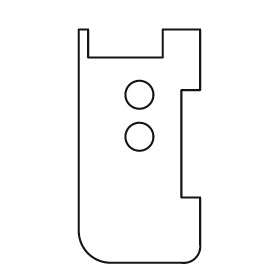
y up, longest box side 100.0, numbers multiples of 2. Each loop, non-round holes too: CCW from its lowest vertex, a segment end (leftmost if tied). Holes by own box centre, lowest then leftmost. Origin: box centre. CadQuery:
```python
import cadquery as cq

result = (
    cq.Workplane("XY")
    .moveTo(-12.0, -50.0)
    .lineTo(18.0, -50.0)
    .threePointArc((24.0, -48.0), (26.0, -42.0))
    .lineTo(26.0, -22.0)
    .lineTo(18.0, -22.0)
    .lineTo(18.0, 24.0)
    .lineTo(26.0, 24.0)
    .lineTo(26.0, 50.0)
    .lineTo(10.0, 50.0)
    .lineTo(10.0, 38.0)
    .lineTo(-22.0, 38.0)
    .lineTo(-22.0, 50.0)
    .lineTo(-26.0, 50.0)
    .lineTo(-26.0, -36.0)
    .threePointArc((-22.0, -46.0), (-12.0, -50.0))
    .close()
    .moveTo(0.0, 4.0)
    .circle(6.0)
    .moveTo(0.0, 22.0)
    .circle(6.0)
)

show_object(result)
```